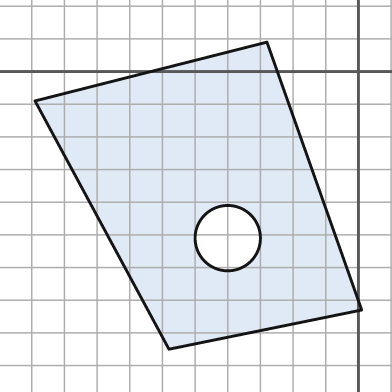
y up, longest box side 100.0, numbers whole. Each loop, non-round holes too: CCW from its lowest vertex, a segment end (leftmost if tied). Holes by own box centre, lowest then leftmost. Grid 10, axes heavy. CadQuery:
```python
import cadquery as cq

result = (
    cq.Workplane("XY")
    .moveTo(-58.0, -85.0)
    .lineTo(1.0, -73.0)
    .lineTo(-28.0, 9.0)
    .lineTo(-99.0, -9.0)
    .close()
    .moveTo(-40.0, -51.0)
    .circle(10.0)
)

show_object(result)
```